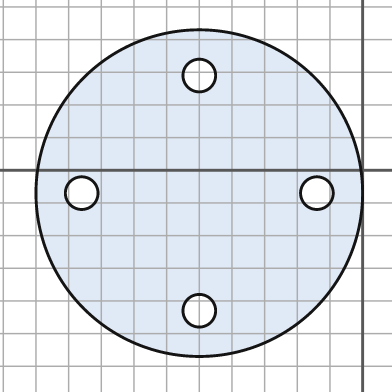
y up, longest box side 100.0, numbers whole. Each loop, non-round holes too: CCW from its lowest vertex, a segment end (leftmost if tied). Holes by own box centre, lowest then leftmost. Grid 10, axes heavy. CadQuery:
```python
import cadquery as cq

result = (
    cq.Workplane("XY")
    .moveTo(-50.0, -7.0)
    .circle(50.0)
    .moveTo(-50.0, -43.0)
    .circle(5.0)
    .moveTo(-86.0, -7.0)
    .circle(5.0)
    .moveTo(-14.0, -7.0)
    .circle(5.0)
    .moveTo(-50.0, 29.0)
    .circle(5.0)
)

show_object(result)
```